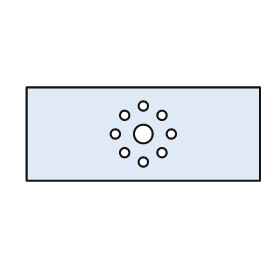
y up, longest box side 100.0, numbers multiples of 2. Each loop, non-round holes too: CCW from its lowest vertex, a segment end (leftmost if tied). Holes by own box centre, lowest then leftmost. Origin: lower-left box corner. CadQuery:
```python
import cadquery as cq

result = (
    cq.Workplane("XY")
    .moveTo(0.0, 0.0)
    .lineTo(100.0, 0.0)
    .lineTo(100.0, 40.0)
    .lineTo(0.0, 40.0)
    .close()
    .moveTo(50.0, 8.0)
    .circle(2.0)
    .moveTo(42.0, 12.0)
    .circle(2.0)
    .moveTo(58.0, 12.0)
    .circle(2.0)
    .moveTo(38.0, 20.0)
    .circle(2.0)
    .moveTo(50.0, 20.0)
    .circle(4.0)
    .moveTo(62.0, 20.0)
    .circle(2.0)
    .moveTo(42.0, 28.0)
    .circle(2.0)
    .moveTo(58.0, 28.0)
    .circle(2.0)
    .moveTo(50.0, 32.0)
    .circle(2.0)
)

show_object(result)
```